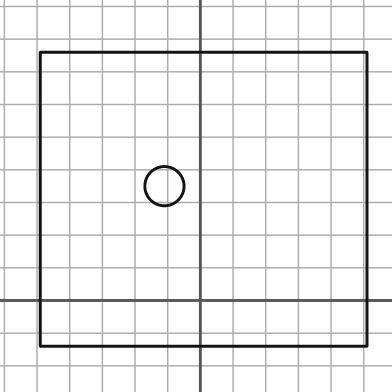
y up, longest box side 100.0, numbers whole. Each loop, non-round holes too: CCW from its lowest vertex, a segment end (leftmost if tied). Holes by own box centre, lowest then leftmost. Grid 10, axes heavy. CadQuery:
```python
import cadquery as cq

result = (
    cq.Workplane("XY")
    .moveTo(-49.0, -14.0)
    .lineTo(51.0, -14.0)
    .lineTo(51.0, 76.0)
    .lineTo(-49.0, 76.0)
    .close()
    .moveTo(-11.0, 35.0)
    .circle(6.0)
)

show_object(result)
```